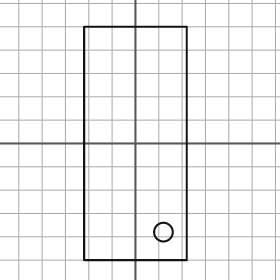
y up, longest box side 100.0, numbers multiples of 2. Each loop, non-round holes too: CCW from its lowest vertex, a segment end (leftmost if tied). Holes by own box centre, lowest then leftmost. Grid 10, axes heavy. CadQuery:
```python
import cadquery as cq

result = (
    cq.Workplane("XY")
    .moveTo(-22.0, -50.0)
    .lineTo(22.0, -50.0)
    .lineTo(22.0, 50.0)
    .lineTo(-22.0, 50.0)
    .close()
    .moveTo(12.0, -38.0)
    .circle(4.0)
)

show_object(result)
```